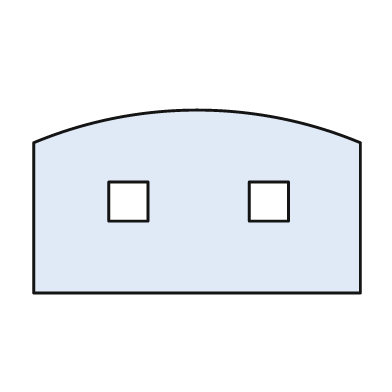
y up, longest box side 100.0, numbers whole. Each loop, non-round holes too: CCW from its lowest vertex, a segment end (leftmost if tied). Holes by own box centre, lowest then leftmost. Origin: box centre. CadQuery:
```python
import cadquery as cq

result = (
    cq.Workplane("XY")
    .moveTo(-50.0, -28.0)
    .lineTo(50.0, -28.0)
    .lineTo(50.0, 18.0)
    .threePointArc((0.0, 28.0), (-50.0, 18.0))
    .close()
    .moveTo(-27.0, -6.0)
    .lineTo(-15.0, -6.0)
    .lineTo(-15.0, 6.0)
    .lineTo(-27.0, 6.0)
    .close()
    .moveTo(16.0, -6.0)
    .lineTo(28.0, -6.0)
    .lineTo(28.0, 6.0)
    .lineTo(16.0, 6.0)
    .close()
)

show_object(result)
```